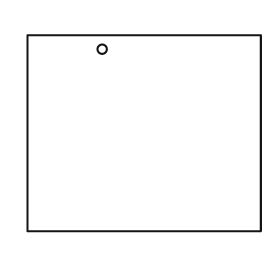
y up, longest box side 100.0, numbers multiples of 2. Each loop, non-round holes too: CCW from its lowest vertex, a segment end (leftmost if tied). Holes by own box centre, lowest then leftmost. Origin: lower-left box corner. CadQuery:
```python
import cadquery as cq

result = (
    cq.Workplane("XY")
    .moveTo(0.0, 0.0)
    .lineTo(100.0, 0.0)
    .lineTo(100.0, 84.0)
    .lineTo(0.0, 84.0)
    .close()
    .moveTo(32.0, 78.0)
    .circle(2.0)
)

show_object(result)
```